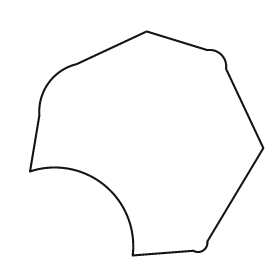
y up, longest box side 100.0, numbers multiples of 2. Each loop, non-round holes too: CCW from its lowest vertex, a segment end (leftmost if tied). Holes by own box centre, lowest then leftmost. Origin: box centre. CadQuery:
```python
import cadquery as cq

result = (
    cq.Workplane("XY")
    .moveTo(-6.0, -48.0)
    .lineTo(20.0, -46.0)
    .threePointArc((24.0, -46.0), (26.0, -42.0))
    .lineTo(50.0, -2.0)
    .lineTo(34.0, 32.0)
    .threePointArc((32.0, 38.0), (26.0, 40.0))
    .lineTo(0.0, 48.0)
    .lineTo(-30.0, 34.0)
    .threePointArc((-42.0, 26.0), (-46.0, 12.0))
    .lineTo(-50.0, -12.0)
    .threePointArc((-18.0, -18.0), (-6.0, -48.0))
    .close()
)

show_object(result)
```